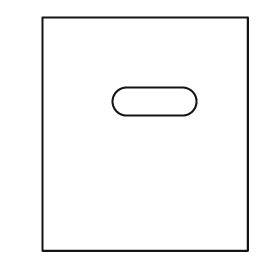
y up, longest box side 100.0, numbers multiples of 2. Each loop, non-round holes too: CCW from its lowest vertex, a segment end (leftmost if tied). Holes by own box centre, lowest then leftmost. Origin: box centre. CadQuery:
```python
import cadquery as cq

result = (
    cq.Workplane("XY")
    .moveTo(-44.0, -50.0)
    .lineTo(44.0, -50.0)
    .lineTo(44.0, 50.0)
    .lineTo(-44.0, 50.0)
    .close()
    .moveTo(-8.0, 8.0)
    .lineTo(16.0, 8.0)
    .threePointArc((22.0, 14.0), (16.0, 20.0))
    .lineTo(-8.0, 20.0)
    .threePointArc((-14.0, 14.0), (-8.0, 8.0))
    .close()
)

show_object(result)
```